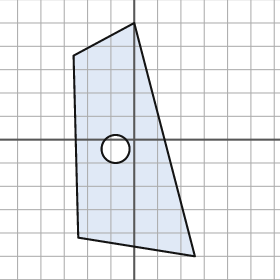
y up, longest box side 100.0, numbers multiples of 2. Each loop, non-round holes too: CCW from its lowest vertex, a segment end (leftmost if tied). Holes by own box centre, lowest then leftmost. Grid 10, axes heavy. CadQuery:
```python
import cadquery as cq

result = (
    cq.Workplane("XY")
    .moveTo(26.0, -50.0)
    .lineTo(0.0, 50.0)
    .lineTo(-26.0, 36.0)
    .lineTo(-24.0, -42.0)
    .close()
    .moveTo(-8.0, -4.0)
    .circle(6.0)
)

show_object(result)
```